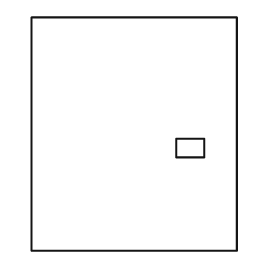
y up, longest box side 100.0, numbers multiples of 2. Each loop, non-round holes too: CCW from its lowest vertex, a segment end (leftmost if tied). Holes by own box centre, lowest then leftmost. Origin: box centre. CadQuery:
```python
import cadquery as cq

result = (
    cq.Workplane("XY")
    .moveTo(-44.0, -50.0)
    .lineTo(44.0, -50.0)
    .lineTo(44.0, 50.0)
    .lineTo(-44.0, 50.0)
    .close()
    .moveTo(18.0, -10.0)
    .lineTo(30.0, -10.0)
    .lineTo(30.0, -2.0)
    .lineTo(18.0, -2.0)
    .close()
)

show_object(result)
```